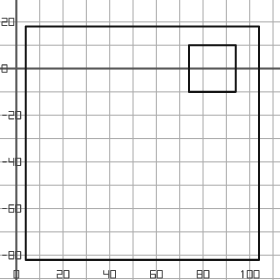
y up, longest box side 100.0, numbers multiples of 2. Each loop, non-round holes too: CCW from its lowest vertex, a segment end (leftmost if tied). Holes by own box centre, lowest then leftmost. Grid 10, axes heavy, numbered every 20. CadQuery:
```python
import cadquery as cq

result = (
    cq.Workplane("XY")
    .moveTo(4.0, -82.0)
    .lineTo(104.0, -82.0)
    .lineTo(104.0, 18.0)
    .lineTo(4.0, 18.0)
    .close()
    .moveTo(74.0, -10.0)
    .lineTo(94.0, -10.0)
    .lineTo(94.0, 10.0)
    .lineTo(74.0, 10.0)
    .close()
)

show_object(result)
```